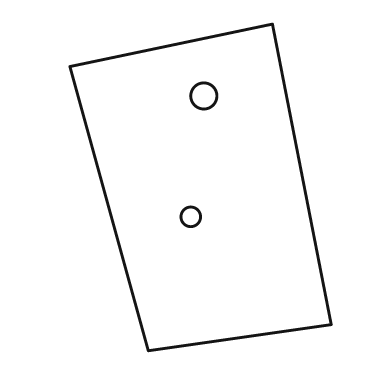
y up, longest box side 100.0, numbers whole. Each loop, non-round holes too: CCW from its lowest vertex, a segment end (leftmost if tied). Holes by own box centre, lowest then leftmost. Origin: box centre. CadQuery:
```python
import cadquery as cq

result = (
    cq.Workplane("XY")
    .moveTo(-16.0, -50.0)
    .lineTo(40.0, -42.0)
    .lineTo(22.0, 50.0)
    .lineTo(-40.0, 37.0)
    .close()
    .moveTo(-3.0, -9.0)
    .circle(3.0)
    .moveTo(1.0, 28.0)
    .circle(4.0)
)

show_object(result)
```